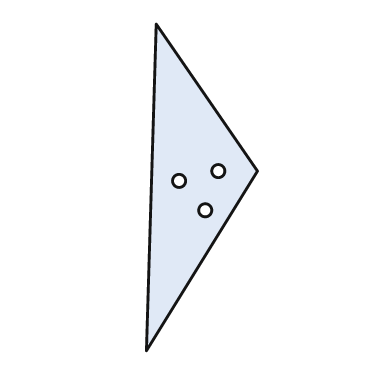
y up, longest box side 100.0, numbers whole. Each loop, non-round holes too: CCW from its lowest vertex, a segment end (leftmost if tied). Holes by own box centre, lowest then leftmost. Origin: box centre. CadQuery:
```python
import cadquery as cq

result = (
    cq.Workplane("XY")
    .moveTo(-17.0, -50.0)
    .lineTo(17.0, 5.0)
    .lineTo(-14.0, 50.0)
    .close()
    .moveTo(1.0, -7.0)
    .circle(2.0)
    .moveTo(-7.0, 2.0)
    .circle(2.0)
    .moveTo(5.0, 5.0)
    .circle(2.0)
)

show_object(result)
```